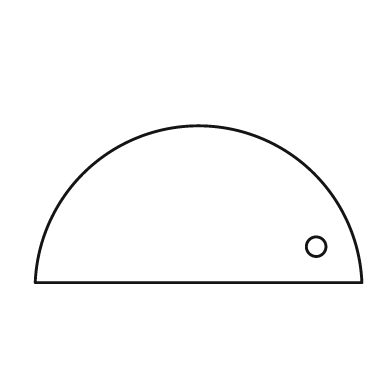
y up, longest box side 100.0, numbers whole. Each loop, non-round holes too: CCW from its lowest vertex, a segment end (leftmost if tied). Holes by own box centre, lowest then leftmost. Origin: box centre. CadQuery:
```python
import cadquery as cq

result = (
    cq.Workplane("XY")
    .moveTo(-50.0, -24.0)
    .lineTo(50.0, -24.0)
    .threePointArc((0.0, 24.0), (-50.0, -24.0))
    .close()
    .moveTo(36.0, -13.0)
    .circle(3.0)
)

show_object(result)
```